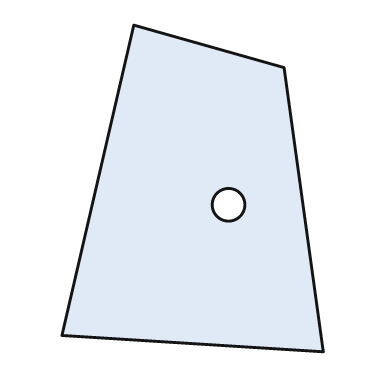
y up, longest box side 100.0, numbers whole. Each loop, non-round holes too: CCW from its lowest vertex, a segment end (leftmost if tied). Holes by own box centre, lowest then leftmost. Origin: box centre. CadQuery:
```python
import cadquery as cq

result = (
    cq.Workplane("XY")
    .moveTo(40.0, -50.0)
    .lineTo(28.0, 37.0)
    .lineTo(-18.0, 50.0)
    .lineTo(-40.0, -45.0)
    .close()
    .moveTo(11.0, -5.0)
    .circle(5.0)
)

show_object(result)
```